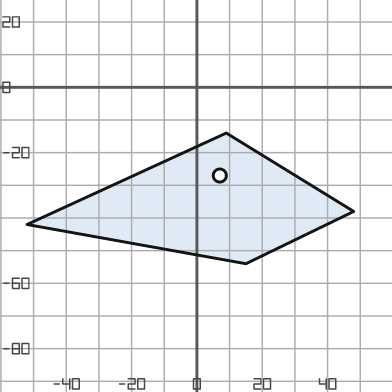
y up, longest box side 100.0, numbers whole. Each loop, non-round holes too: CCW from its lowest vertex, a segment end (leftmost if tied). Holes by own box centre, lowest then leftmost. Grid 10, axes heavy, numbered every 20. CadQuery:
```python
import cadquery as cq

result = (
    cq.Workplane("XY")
    .moveTo(15.0, -54.0)
    .lineTo(48.0, -38.0)
    .lineTo(9.0, -14.0)
    .lineTo(-52.0, -42.0)
    .close()
    .moveTo(7.0, -27.0)
    .circle(2.0)
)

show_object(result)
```